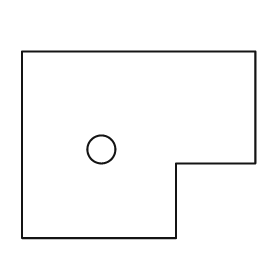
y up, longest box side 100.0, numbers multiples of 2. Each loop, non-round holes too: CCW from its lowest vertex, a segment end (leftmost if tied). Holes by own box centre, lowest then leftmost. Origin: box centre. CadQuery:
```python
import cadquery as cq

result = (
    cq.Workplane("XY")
    .moveTo(-50.0, -40.0)
    .lineTo(16.0, -40.0)
    .lineTo(16.0, -8.0)
    .lineTo(50.0, -8.0)
    .lineTo(50.0, 40.0)
    .lineTo(-50.0, 40.0)
    .close()
    .moveTo(-16.0, -2.0)
    .circle(6.0)
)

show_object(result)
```